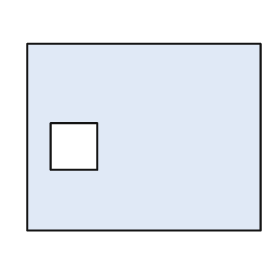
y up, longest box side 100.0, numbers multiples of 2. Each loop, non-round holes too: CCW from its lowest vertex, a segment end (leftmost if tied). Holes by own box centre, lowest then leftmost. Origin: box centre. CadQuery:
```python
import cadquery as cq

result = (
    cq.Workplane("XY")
    .moveTo(-50.0, -40.0)
    .lineTo(50.0, -40.0)
    .lineTo(50.0, 40.0)
    .lineTo(-50.0, 40.0)
    .close()
    .moveTo(-40.0, -14.0)
    .lineTo(-20.0, -14.0)
    .lineTo(-20.0, 6.0)
    .lineTo(-40.0, 6.0)
    .close()
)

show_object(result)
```